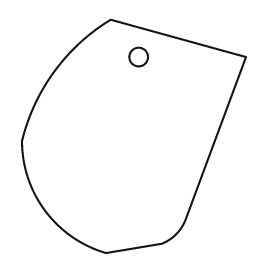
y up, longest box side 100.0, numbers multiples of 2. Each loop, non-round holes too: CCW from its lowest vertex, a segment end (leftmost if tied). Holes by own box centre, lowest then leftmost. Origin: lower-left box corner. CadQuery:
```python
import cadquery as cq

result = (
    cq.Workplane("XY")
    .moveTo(36.0, 0.0)
    .lineTo(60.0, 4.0)
    .threePointArc((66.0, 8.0), (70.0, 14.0))
    .lineTo(96.0, 84.0)
    .lineTo(38.0, 100.0)
    .threePointArc((14.0, 78.0), (0.0, 48.0))
    .threePointArc((10.0, 18.0), (36.0, 0.0))
    .close()
    .moveTo(50.0, 84.0)
    .circle(4.0)
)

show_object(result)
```